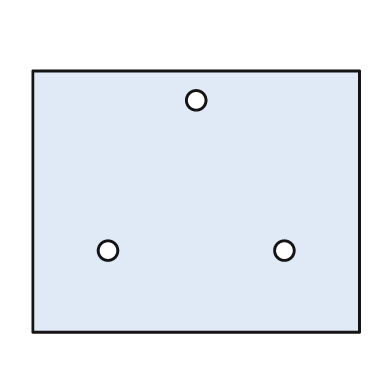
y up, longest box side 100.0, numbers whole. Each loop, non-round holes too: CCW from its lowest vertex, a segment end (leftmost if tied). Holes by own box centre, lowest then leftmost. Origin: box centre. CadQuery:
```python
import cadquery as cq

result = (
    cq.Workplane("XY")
    .moveTo(-50.0, -40.0)
    .lineTo(50.0, -40.0)
    .lineTo(50.0, 40.0)
    .lineTo(-50.0, 40.0)
    .close()
    .moveTo(-27.0, -15.0)
    .circle(3.0)
    .moveTo(27.0, -15.0)
    .circle(3.0)
    .moveTo(0.0, 31.0)
    .circle(3.0)
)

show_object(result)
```